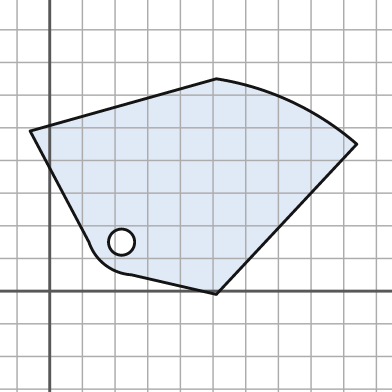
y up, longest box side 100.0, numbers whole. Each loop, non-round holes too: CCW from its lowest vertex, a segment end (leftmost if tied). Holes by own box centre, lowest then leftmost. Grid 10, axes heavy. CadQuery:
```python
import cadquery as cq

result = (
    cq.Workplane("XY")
    .moveTo(51.0, -1.0)
    .lineTo(94.0, 45.0)
    .threePointArc((74.0, 58.0), (51.0, 65.0))
    .lineTo(-6.0, 49.0)
    .lineTo(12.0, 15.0)
    .threePointArc((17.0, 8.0), (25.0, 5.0))
    .close()
    .moveTo(22.0, 15.0)
    .circle(4.0)
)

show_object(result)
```